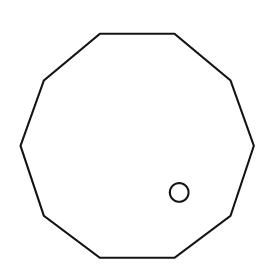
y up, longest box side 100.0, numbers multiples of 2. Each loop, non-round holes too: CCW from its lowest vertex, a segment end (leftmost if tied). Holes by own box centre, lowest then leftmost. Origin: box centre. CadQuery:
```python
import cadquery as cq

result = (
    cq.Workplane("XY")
    .moveTo(-16.0, -48.0)
    .lineTo(16.0, -48.0)
    .lineTo(40.0, -30.0)
    .lineTo(50.0, 0.0)
    .lineTo(40.0, 28.0)
    .lineTo(16.0, 48.0)
    .lineTo(-16.0, 48.0)
    .lineTo(-40.0, 28.0)
    .lineTo(-50.0, 0.0)
    .lineTo(-40.0, -30.0)
    .close()
    .moveTo(18.0, -20.0)
    .circle(4.0)
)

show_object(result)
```